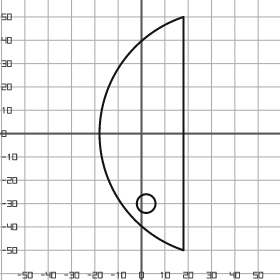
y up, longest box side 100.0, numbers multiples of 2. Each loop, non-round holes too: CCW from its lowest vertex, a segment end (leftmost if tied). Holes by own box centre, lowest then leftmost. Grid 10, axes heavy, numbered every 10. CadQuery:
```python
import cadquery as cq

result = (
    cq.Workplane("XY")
    .moveTo(18.0, -50.0)
    .lineTo(18.0, 50.0)
    .threePointArc((-18.0, 0.0), (18.0, -50.0))
    .close()
    .moveTo(2.0, -30.0)
    .circle(4.0)
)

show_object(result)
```